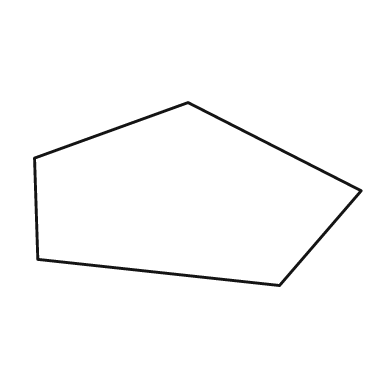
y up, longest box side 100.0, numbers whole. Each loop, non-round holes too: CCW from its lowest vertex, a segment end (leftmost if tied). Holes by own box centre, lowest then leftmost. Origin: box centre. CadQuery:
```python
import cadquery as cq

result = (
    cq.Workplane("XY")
    .moveTo(25.0, -28.0)
    .lineTo(50.0, 1.0)
    .lineTo(-3.0, 28.0)
    .lineTo(-50.0, 11.0)
    .lineTo(-49.0, -20.0)
    .close()
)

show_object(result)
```